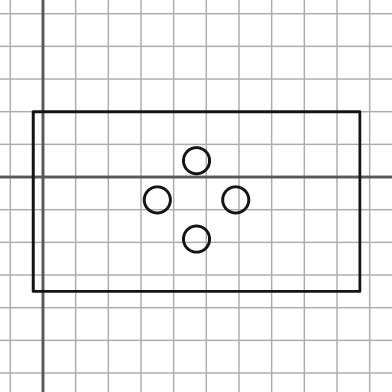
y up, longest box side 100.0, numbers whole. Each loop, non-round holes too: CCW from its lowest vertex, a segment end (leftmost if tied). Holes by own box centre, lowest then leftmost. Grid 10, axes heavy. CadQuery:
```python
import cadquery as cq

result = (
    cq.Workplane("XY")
    .moveTo(-3.0, -35.0)
    .lineTo(97.0, -35.0)
    .lineTo(97.0, 20.0)
    .lineTo(-3.0, 20.0)
    .close()
    .moveTo(47.0, -19.0)
    .circle(4.0)
    .moveTo(35.0, -7.0)
    .circle(4.0)
    .moveTo(59.0, -7.0)
    .circle(4.0)
    .moveTo(47.0, 5.0)
    .circle(4.0)
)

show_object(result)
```